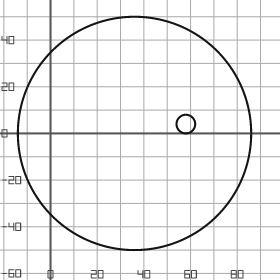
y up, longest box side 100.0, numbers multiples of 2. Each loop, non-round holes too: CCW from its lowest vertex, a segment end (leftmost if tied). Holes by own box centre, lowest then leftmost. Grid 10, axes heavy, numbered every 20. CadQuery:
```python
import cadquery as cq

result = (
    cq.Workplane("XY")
    .moveTo(36.0, 0.0)
    .circle(50.0)
    .moveTo(58.0, 4.0)
    .circle(4.0)
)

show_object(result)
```